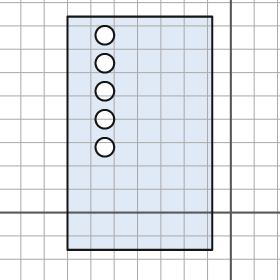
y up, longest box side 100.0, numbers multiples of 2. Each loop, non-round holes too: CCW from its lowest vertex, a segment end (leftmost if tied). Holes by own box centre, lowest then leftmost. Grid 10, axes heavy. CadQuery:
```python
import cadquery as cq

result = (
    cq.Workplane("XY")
    .moveTo(-70.0, -16.0)
    .lineTo(-8.0, -16.0)
    .lineTo(-8.0, 84.0)
    .lineTo(-70.0, 84.0)
    .close()
    .moveTo(-54.0, 28.0)
    .circle(4.0)
    .moveTo(-54.0, 40.0)
    .circle(4.0)
    .moveTo(-54.0, 52.0)
    .circle(4.0)
    .moveTo(-54.0, 64.0)
    .circle(4.0)
    .moveTo(-54.0, 76.0)
    .circle(4.0)
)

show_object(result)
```